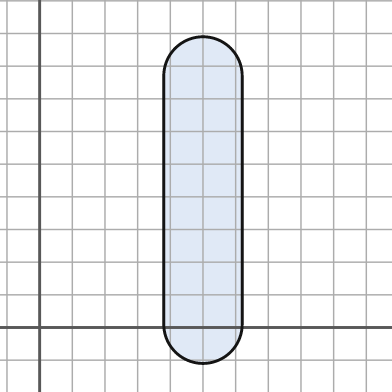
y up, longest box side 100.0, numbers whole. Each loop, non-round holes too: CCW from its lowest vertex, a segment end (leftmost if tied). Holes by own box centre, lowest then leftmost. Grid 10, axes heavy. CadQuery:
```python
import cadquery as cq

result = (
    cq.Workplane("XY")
    .moveTo(38.0, 1.0)
    .threePointArc((50.0, -11.0), (62.0, 1.0))
    .lineTo(62.0, 77.0)
    .threePointArc((50.0, 89.0), (38.0, 77.0))
    .close()
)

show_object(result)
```